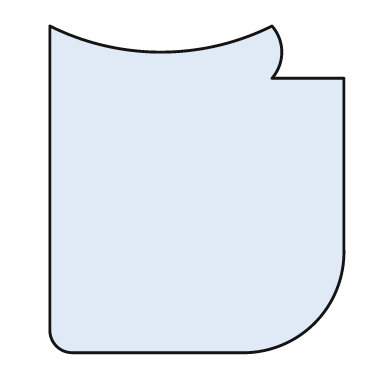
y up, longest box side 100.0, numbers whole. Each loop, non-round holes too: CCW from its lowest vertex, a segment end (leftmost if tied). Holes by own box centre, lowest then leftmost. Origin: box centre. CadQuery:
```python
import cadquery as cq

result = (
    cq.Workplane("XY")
    .moveTo(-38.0, -50.0)
    .lineTo(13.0, -50.0)
    .threePointArc((36.0, -41.0), (45.0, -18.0))
    .lineTo(45.0, 34.0)
    .lineTo(23.0, 34.0)
    .threePointArc((26.0, 42.0), (23.0, 50.0))
    .threePointArc((-11.0, 42.0), (-45.0, 50.0))
    .lineTo(-45.0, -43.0)
    .threePointArc((-43.0, -48.0), (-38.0, -50.0))
    .close()
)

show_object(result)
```